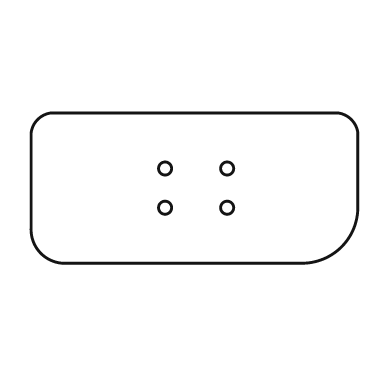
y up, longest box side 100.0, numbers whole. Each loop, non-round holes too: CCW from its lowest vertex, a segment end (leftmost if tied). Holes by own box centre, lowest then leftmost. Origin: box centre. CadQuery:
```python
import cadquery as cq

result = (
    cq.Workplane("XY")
    .moveTo(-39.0, -23.0)
    .lineTo(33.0, -23.0)
    .threePointArc((45.0, -18.0), (50.0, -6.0))
    .lineTo(50.0, 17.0)
    .threePointArc((48.0, 21.0), (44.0, 23.0))
    .lineTo(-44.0, 23.0)
    .threePointArc((-48.0, 21.0), (-50.0, 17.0))
    .lineTo(-50.0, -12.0)
    .threePointArc((-47.0, -20.0), (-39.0, -23.0))
    .close()
    .moveTo(-9.0, -6.0)
    .circle(2.0)
    .moveTo(10.0, -6.0)
    .circle(2.0)
    .moveTo(-9.0, 6.0)
    .circle(2.0)
    .moveTo(10.0, 6.0)
    .circle(2.0)
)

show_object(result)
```